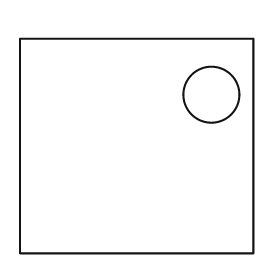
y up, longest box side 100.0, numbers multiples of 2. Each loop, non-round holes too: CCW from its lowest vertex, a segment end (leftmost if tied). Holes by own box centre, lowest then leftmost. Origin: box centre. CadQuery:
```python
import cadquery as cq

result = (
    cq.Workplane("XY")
    .moveTo(-50.0, -46.0)
    .lineTo(50.0, -46.0)
    .lineTo(50.0, 46.0)
    .lineTo(-50.0, 46.0)
    .close()
    .moveTo(32.0, 22.0)
    .circle(12.0)
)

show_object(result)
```